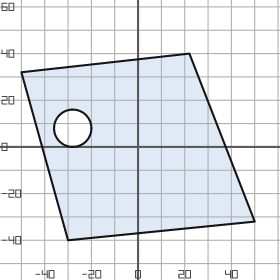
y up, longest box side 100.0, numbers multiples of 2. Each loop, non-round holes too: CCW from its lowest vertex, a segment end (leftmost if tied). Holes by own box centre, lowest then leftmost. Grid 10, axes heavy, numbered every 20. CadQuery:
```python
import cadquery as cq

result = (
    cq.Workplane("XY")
    .moveTo(-30.0, -40.0)
    .lineTo(50.0, -32.0)
    .lineTo(22.0, 40.0)
    .lineTo(-50.0, 32.0)
    .close()
    .moveTo(-28.0, 8.0)
    .circle(8.0)
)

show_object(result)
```